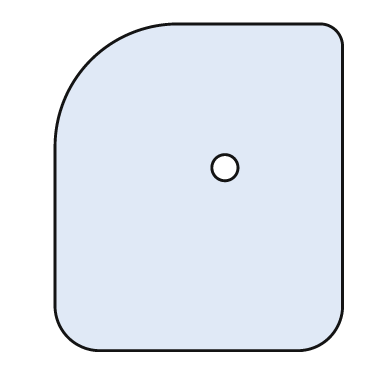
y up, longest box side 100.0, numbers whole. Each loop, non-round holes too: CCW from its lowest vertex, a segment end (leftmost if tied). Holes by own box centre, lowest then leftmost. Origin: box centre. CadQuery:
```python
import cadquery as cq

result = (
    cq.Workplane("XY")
    .moveTo(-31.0, -50.0)
    .lineTo(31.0, -50.0)
    .threePointArc((40.0, -46.0), (44.0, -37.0))
    .lineTo(44.0, 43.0)
    .threePointArc((42.0, 48.0), (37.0, 50.0))
    .lineTo(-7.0, 50.0)
    .threePointArc((-33.0, 39.0), (-44.0, 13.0))
    .lineTo(-44.0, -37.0)
    .threePointArc((-40.0, -46.0), (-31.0, -50.0))
    .close()
    .moveTo(8.0, 6.0)
    .circle(4.0)
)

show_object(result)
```